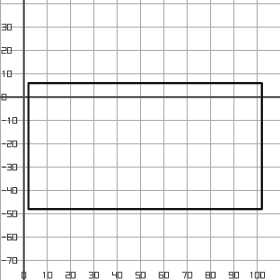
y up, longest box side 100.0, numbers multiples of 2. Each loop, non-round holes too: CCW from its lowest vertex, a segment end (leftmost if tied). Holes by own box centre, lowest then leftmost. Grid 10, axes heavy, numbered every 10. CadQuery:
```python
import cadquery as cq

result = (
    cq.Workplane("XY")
    .moveTo(2.0, -48.0)
    .lineTo(102.0, -48.0)
    .lineTo(102.0, 6.0)
    .lineTo(2.0, 6.0)
    .close()
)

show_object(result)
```